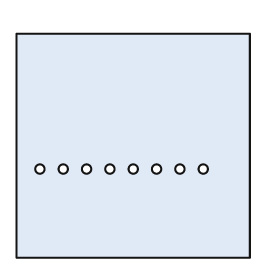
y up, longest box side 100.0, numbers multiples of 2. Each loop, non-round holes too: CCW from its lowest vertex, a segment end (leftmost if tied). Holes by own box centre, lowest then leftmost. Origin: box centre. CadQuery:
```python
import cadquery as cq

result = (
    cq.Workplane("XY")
    .moveTo(-50.0, -48.0)
    .lineTo(50.0, -48.0)
    .lineTo(50.0, 48.0)
    .lineTo(-50.0, 48.0)
    .close()
    .moveTo(-40.0, -10.0)
    .circle(2.0)
    .moveTo(-30.0, -10.0)
    .circle(2.0)
    .moveTo(-20.0, -10.0)
    .circle(2.0)
    .moveTo(-10.0, -10.0)
    .circle(2.0)
    .moveTo(0.0, -10.0)
    .circle(2.0)
    .moveTo(10.0, -10.0)
    .circle(2.0)
    .moveTo(20.0, -10.0)
    .circle(2.0)
    .moveTo(30.0, -10.0)
    .circle(2.0)
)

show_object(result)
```